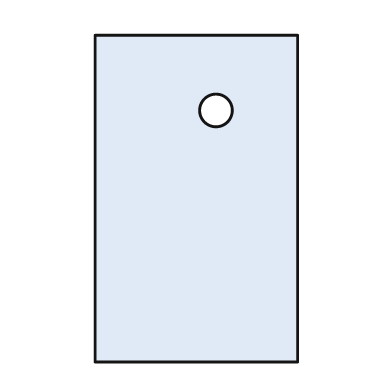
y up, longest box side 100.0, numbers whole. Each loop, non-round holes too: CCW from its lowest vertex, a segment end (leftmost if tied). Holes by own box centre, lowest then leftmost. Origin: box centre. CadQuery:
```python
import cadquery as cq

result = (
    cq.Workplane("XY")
    .moveTo(-31.0, -50.0)
    .lineTo(31.0, -50.0)
    .lineTo(31.0, 50.0)
    .lineTo(-31.0, 50.0)
    .close()
    .moveTo(6.0, 27.0)
    .circle(5.0)
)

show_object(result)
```